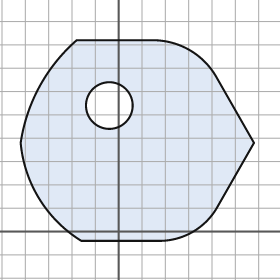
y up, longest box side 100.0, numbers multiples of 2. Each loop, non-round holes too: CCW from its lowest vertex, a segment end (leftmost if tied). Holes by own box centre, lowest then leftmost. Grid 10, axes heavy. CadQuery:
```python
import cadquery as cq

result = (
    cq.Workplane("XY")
    .moveTo(-16.0, -4.0)
    .lineTo(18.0, -4.0)
    .threePointArc((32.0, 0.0), (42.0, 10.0))
    .lineTo(58.0, 38.0)
    .lineTo(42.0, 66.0)
    .threePointArc((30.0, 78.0), (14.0, 82.0))
    .lineTo(-18.0, 82.0)
    .threePointArc((-34.0, 62.0), (-42.0, 38.0))
    .threePointArc((-34.0, 14.0), (-16.0, -4.0))
    .close()
    .moveTo(-4.0, 54.0)
    .circle(10.0)
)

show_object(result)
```